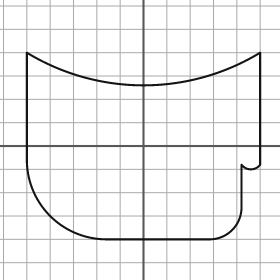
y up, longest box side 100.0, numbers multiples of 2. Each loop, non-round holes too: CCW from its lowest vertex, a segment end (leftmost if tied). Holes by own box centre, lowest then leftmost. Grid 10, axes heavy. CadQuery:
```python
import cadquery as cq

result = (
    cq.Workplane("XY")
    .moveTo(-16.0, -40.0)
    .lineTo(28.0, -40.0)
    .threePointArc((38.0, -36.0), (42.0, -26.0))
    .lineTo(42.0, -8.0)
    .threePointArc((46.0, -10.0), (50.0, -8.0))
    .lineTo(50.0, 40.0)
    .threePointArc((0.0, 26.0), (-50.0, 40.0))
    .lineTo(-50.0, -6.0)
    .threePointArc((-40.0, -30.0), (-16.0, -40.0))
    .close()
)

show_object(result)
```